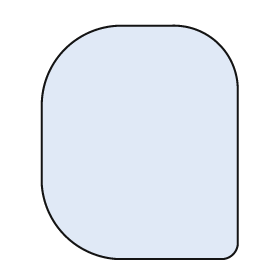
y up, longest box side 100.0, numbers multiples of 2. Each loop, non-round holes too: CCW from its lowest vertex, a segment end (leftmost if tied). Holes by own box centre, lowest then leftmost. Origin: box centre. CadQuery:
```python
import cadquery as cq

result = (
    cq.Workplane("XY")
    .moveTo(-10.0, -50.0)
    .lineTo(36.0, -50.0)
    .threePointArc((40.0, -48.0), (42.0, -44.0))
    .lineTo(42.0, 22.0)
    .threePointArc((34.0, 42.0), (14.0, 50.0))
    .lineTo(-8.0, 50.0)
    .threePointArc((-32.0, 40.0), (-42.0, 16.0))
    .lineTo(-42.0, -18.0)
    .threePointArc((-32.0, -40.0), (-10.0, -50.0))
    .close()
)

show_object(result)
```